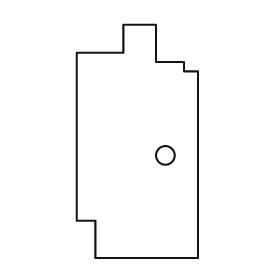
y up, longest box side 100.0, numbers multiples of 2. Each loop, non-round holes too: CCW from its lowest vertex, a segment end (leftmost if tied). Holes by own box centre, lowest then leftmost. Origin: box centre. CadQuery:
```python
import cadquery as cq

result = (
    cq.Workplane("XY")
    .moveTo(-18.0, -50.0)
    .lineTo(26.0, -50.0)
    .lineTo(26.0, 30.0)
    .lineTo(20.0, 30.0)
    .lineTo(20.0, 34.0)
    .lineTo(8.0, 34.0)
    .lineTo(8.0, 50.0)
    .lineTo(-6.0, 50.0)
    .lineTo(-6.0, 38.0)
    .lineTo(-26.0, 38.0)
    .lineTo(-26.0, -34.0)
    .lineTo(-18.0, -34.0)
    .close()
    .moveTo(12.0, -6.0)
    .circle(4.0)
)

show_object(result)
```